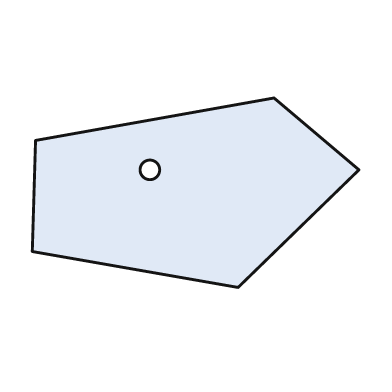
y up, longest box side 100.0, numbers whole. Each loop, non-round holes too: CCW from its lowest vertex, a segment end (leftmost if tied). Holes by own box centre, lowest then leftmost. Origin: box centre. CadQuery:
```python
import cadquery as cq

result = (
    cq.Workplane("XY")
    .moveTo(13.0, -29.0)
    .lineTo(50.0, 7.0)
    .lineTo(24.0, 29.0)
    .lineTo(-49.0, 16.0)
    .lineTo(-50.0, -18.0)
    .close()
    .moveTo(-14.0, 7.0)
    .circle(3.0)
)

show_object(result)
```